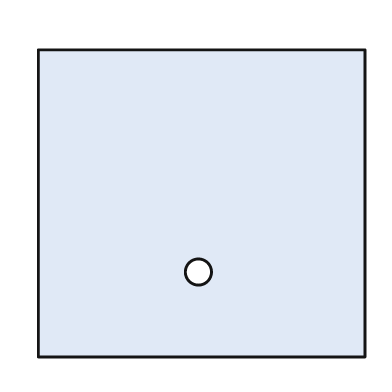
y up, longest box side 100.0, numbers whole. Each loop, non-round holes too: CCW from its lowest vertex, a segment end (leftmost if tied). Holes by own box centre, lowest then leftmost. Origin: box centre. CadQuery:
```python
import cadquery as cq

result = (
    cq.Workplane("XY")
    .moveTo(-50.0, -47.0)
    .lineTo(50.0, -47.0)
    .lineTo(50.0, 47.0)
    .lineTo(-50.0, 47.0)
    .close()
    .moveTo(-1.0, -21.0)
    .circle(4.0)
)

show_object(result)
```